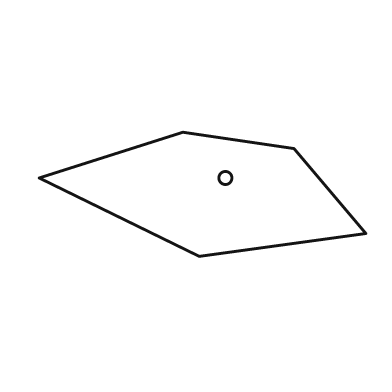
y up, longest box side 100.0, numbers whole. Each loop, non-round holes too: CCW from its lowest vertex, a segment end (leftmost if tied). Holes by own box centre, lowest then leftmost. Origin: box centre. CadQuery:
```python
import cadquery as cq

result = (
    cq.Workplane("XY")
    .moveTo(-1.0, -19.0)
    .lineTo(50.0, -12.0)
    .lineTo(28.0, 14.0)
    .lineTo(-6.0, 19.0)
    .lineTo(-50.0, 5.0)
    .close()
    .moveTo(7.0, 5.0)
    .circle(2.0)
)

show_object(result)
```